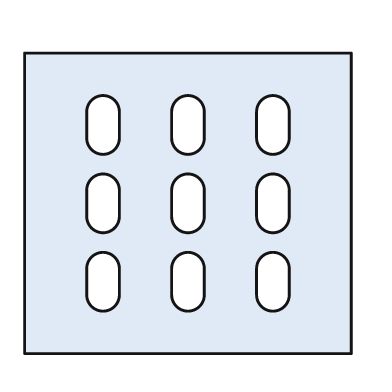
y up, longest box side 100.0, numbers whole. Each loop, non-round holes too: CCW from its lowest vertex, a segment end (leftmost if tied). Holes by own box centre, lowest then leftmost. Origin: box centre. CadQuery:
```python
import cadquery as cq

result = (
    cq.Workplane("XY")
    .moveTo(-50.0, -46.0)
    .lineTo(50.0, -46.0)
    .lineTo(50.0, 46.0)
    .lineTo(-50.0, 46.0)
    .close()
    .moveTo(-31.0, -28.0)
    .threePointArc((-26.0, -33.0), (-21.0, -28.0))
    .lineTo(-21.0, -20.0)
    .threePointArc((-26.0, -15.0), (-31.0, -20.0))
    .close()
    .moveTo(-5.0, -28.0)
    .threePointArc((0.0, -33.0), (5.0, -28.0))
    .lineTo(5.0, -20.0)
    .threePointArc((0.0, -15.0), (-5.0, -20.0))
    .close()
    .moveTo(21.0, -28.0)
    .threePointArc((26.0, -33.0), (31.0, -28.0))
    .lineTo(31.0, -20.0)
    .threePointArc((26.0, -15.0), (21.0, -20.0))
    .close()
    .moveTo(-31.0, -4.0)
    .threePointArc((-26.0, -9.0), (-21.0, -4.0))
    .lineTo(-21.0, 4.0)
    .threePointArc((-26.0, 9.0), (-31.0, 4.0))
    .close()
    .moveTo(-5.0, -4.0)
    .threePointArc((0.0, -9.0), (5.0, -4.0))
    .lineTo(5.0, 4.0)
    .threePointArc((0.0, 9.0), (-5.0, 4.0))
    .close()
    .moveTo(21.0, -4.0)
    .threePointArc((26.0, -9.0), (31.0, -4.0))
    .lineTo(31.0, 4.0)
    .threePointArc((26.0, 9.0), (21.0, 4.0))
    .close()
    .moveTo(-31.0, 20.0)
    .threePointArc((-26.0, 15.0), (-21.0, 20.0))
    .lineTo(-21.0, 28.0)
    .threePointArc((-26.0, 33.0), (-31.0, 28.0))
    .close()
    .moveTo(-5.0, 20.0)
    .threePointArc((0.0, 15.0), (5.0, 20.0))
    .lineTo(5.0, 28.0)
    .threePointArc((0.0, 33.0), (-5.0, 28.0))
    .close()
    .moveTo(21.0, 20.0)
    .threePointArc((26.0, 15.0), (31.0, 20.0))
    .lineTo(31.0, 28.0)
    .threePointArc((26.0, 33.0), (21.0, 28.0))
    .close()
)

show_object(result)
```